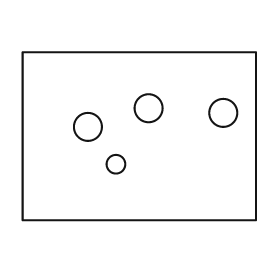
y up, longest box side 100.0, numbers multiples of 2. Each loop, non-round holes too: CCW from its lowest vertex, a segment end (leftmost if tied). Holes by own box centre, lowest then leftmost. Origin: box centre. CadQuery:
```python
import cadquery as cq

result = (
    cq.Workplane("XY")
    .moveTo(-50.0, -36.0)
    .lineTo(50.0, -36.0)
    .lineTo(50.0, 36.0)
    .lineTo(-50.0, 36.0)
    .close()
    .moveTo(-10.0, -12.0)
    .circle(4.0)
    .moveTo(-22.0, 4.0)
    .circle(6.0)
    .moveTo(36.0, 10.0)
    .circle(6.0)
    .moveTo(4.0, 12.0)
    .circle(6.0)
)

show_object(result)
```